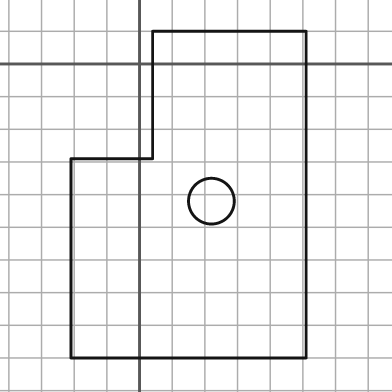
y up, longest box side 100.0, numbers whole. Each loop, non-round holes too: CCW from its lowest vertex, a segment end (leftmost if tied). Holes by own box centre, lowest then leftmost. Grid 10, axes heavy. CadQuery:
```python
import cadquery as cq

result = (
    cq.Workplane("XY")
    .moveTo(-21.0, -90.0)
    .lineTo(51.0, -90.0)
    .lineTo(51.0, 10.0)
    .lineTo(4.0, 10.0)
    .lineTo(4.0, -29.0)
    .lineTo(-21.0, -29.0)
    .close()
    .moveTo(22.0, -42.0)
    .circle(7.0)
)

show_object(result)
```